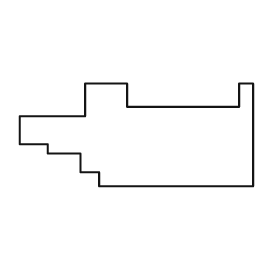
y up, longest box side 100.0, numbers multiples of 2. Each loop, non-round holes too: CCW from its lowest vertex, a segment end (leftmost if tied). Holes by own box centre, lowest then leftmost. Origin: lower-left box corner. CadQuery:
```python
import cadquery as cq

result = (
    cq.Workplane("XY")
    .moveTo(34.0, 0.0)
    .lineTo(100.0, 0.0)
    .lineTo(100.0, 44.0)
    .lineTo(94.0, 44.0)
    .lineTo(94.0, 34.0)
    .lineTo(46.0, 34.0)
    .lineTo(46.0, 44.0)
    .lineTo(28.0, 44.0)
    .lineTo(28.0, 30.0)
    .lineTo(0.0, 30.0)
    .lineTo(0.0, 18.0)
    .lineTo(12.0, 18.0)
    .lineTo(12.0, 14.0)
    .lineTo(26.0, 14.0)
    .lineTo(26.0, 6.0)
    .lineTo(34.0, 6.0)
    .close()
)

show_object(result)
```